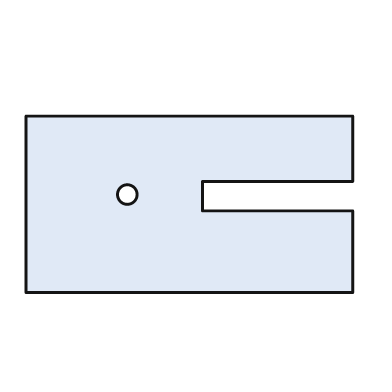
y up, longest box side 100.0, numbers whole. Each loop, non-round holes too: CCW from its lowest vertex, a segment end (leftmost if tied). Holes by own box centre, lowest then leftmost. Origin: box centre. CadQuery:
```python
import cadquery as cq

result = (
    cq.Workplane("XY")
    .moveTo(-50.0, -27.0)
    .lineTo(50.0, -27.0)
    .lineTo(50.0, -2.0)
    .lineTo(4.0, -2.0)
    .lineTo(4.0, 7.0)
    .lineTo(50.0, 7.0)
    .lineTo(50.0, 27.0)
    .lineTo(-50.0, 27.0)
    .close()
    .moveTo(-19.0, 3.0)
    .circle(3.0)
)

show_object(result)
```